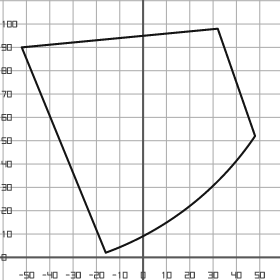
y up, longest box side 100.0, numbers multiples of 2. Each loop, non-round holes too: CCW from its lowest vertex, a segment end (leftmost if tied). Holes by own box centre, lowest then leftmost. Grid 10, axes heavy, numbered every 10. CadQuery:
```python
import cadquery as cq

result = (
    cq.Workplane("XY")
    .moveTo(-16.0, 2.0)
    .threePointArc((20.0, 22.0), (48.0, 52.0))
    .lineTo(32.0, 98.0)
    .lineTo(-52.0, 90.0)
    .close()
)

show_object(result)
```